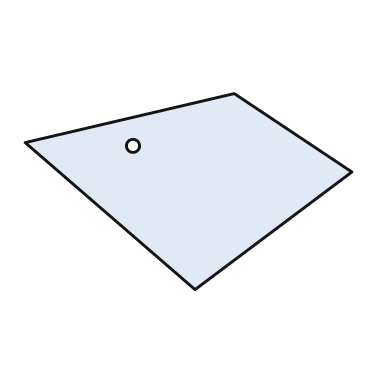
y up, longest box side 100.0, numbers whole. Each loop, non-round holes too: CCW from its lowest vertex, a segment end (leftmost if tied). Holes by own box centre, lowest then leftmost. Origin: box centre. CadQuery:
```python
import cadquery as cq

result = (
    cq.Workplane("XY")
    .moveTo(2.0, -30.0)
    .lineTo(50.0, 6.0)
    .lineTo(14.0, 30.0)
    .lineTo(-50.0, 15.0)
    .close()
    .moveTo(-17.0, 14.0)
    .circle(2.0)
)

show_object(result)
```